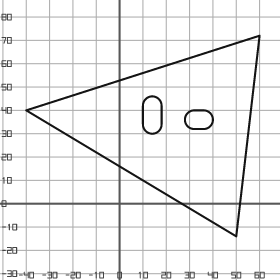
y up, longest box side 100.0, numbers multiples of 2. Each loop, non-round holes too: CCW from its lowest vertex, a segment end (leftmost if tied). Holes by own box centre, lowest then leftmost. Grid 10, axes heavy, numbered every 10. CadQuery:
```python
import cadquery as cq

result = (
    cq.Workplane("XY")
    .moveTo(50.0, -14.0)
    .lineTo(60.0, 72.0)
    .lineTo(-40.0, 40.0)
    .close()
    .moveTo(32.0, 32.0)
    .lineTo(36.0, 32.0)
    .threePointArc((40.0, 36.0), (36.0, 40.0))
    .lineTo(32.0, 40.0)
    .threePointArc((28.0, 36.0), (32.0, 32.0))
    .close()
    .moveTo(10.0, 34.0)
    .threePointArc((14.0, 30.0), (18.0, 34.0))
    .lineTo(18.0, 42.0)
    .threePointArc((14.0, 46.0), (10.0, 42.0))
    .close()
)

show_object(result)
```